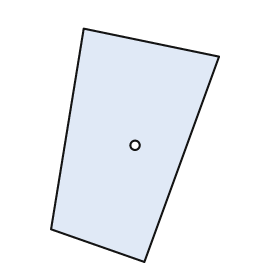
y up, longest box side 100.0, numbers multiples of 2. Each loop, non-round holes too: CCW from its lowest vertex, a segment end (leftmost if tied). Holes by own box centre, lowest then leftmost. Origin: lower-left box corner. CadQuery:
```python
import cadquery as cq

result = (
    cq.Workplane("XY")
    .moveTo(40.0, 0.0)
    .lineTo(72.0, 88.0)
    .lineTo(14.0, 100.0)
    .lineTo(0.0, 14.0)
    .close()
    .moveTo(36.0, 50.0)
    .circle(2.0)
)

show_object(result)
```